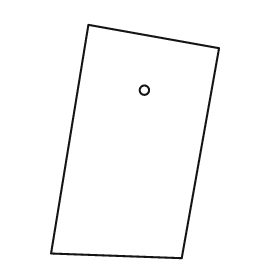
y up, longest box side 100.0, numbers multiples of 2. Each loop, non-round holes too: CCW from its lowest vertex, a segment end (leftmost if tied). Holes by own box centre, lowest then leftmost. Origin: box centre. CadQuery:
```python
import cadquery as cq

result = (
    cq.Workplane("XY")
    .moveTo(20.0, -50.0)
    .lineTo(36.0, 40.0)
    .lineTo(-20.0, 50.0)
    .lineTo(-36.0, -48.0)
    .close()
    .moveTo(4.0, 22.0)
    .circle(2.0)
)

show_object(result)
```